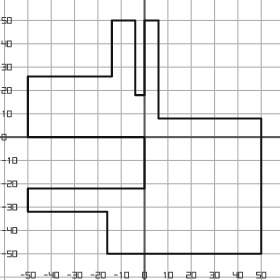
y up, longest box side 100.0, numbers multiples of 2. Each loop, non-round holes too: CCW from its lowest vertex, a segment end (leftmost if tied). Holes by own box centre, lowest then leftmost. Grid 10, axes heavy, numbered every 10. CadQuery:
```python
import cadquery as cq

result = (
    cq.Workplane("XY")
    .moveTo(-16.0, -50.0)
    .lineTo(50.0, -50.0)
    .lineTo(50.0, 8.0)
    .lineTo(6.0, 8.0)
    .lineTo(6.0, 50.0)
    .lineTo(0.0, 50.0)
    .lineTo(0.0, 18.0)
    .lineTo(-4.0, 18.0)
    .lineTo(-4.0, 50.0)
    .lineTo(-14.0, 50.0)
    .lineTo(-14.0, 26.0)
    .lineTo(-50.0, 26.0)
    .lineTo(-50.0, 0.0)
    .lineTo(0.0, 0.0)
    .lineTo(0.0, -22.0)
    .lineTo(-50.0, -22.0)
    .lineTo(-50.0, -32.0)
    .lineTo(-16.0, -32.0)
    .close()
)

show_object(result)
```